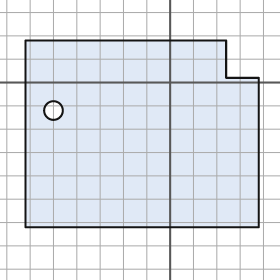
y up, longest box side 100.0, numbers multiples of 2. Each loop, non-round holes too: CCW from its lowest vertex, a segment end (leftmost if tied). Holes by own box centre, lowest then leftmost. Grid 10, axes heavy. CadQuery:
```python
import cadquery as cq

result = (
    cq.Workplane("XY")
    .moveTo(-62.0, -62.0)
    .lineTo(38.0, -62.0)
    .lineTo(38.0, 2.0)
    .lineTo(24.0, 2.0)
    .lineTo(24.0, 18.0)
    .lineTo(-62.0, 18.0)
    .close()
    .moveTo(-50.0, -12.0)
    .circle(4.0)
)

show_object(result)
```